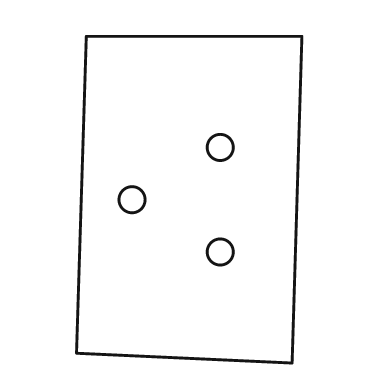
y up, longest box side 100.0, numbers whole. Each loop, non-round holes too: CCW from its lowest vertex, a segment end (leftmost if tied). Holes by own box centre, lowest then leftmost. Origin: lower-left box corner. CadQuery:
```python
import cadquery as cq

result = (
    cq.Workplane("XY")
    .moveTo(66.0, 0.0)
    .lineTo(69.0, 100.0)
    .lineTo(3.0, 100.0)
    .lineTo(0.0, 3.0)
    .close()
    .moveTo(44.0, 34.0)
    .circle(4.0)
    .moveTo(17.0, 50.0)
    .circle(4.0)
    .moveTo(44.0, 66.0)
    .circle(4.0)
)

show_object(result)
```